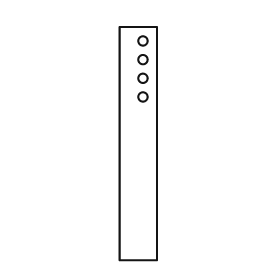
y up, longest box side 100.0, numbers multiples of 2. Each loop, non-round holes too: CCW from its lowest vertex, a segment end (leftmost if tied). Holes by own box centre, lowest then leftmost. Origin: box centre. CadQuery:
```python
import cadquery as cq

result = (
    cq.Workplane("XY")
    .moveTo(-8.0, -50.0)
    .lineTo(8.0, -50.0)
    .lineTo(8.0, 50.0)
    .lineTo(-8.0, 50.0)
    .close()
    .moveTo(2.0, 20.0)
    .circle(2.0)
    .moveTo(2.0, 28.0)
    .circle(2.0)
    .moveTo(2.0, 36.0)
    .circle(2.0)
    .moveTo(2.0, 44.0)
    .circle(2.0)
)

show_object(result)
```